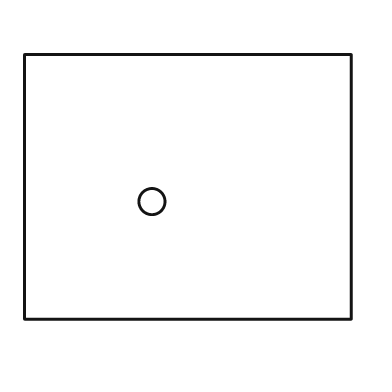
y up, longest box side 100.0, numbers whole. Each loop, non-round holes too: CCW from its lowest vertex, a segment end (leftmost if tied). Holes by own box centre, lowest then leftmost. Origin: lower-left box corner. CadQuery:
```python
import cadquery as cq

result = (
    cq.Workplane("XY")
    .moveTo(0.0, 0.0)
    .lineTo(100.0, 0.0)
    .lineTo(100.0, 81.0)
    .lineTo(0.0, 81.0)
    .close()
    .moveTo(39.0, 36.0)
    .circle(4.0)
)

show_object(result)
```